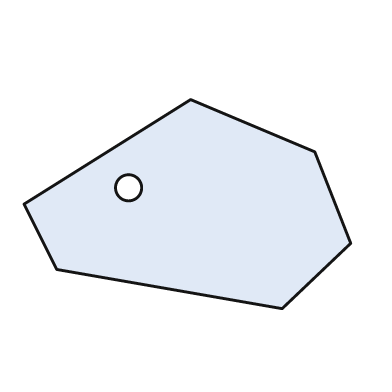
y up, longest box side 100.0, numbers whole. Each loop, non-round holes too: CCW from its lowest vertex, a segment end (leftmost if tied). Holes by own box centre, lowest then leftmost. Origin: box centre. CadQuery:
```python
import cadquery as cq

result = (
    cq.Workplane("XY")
    .moveTo(29.0, -32.0)
    .lineTo(50.0, -12.0)
    .lineTo(39.0, 16.0)
    .lineTo(1.0, 32.0)
    .lineTo(-50.0, 0.0)
    .lineTo(-40.0, -20.0)
    .close()
    .moveTo(-18.0, 5.0)
    .circle(4.0)
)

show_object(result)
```